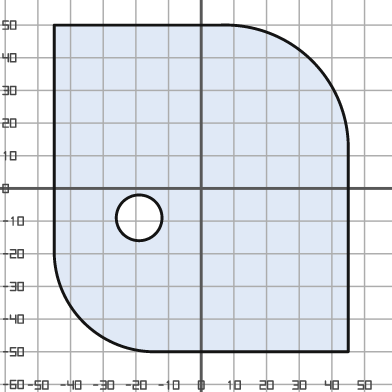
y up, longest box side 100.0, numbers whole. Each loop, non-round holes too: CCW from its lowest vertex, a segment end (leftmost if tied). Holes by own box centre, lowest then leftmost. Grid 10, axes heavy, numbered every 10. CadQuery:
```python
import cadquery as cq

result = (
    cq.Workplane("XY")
    .moveTo(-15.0, -50.0)
    .lineTo(45.0, -50.0)
    .lineTo(45.0, 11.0)
    .threePointArc((34.0, 39.0), (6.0, 50.0))
    .lineTo(-45.0, 50.0)
    .lineTo(-45.0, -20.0)
    .threePointArc((-36.0, -41.0), (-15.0, -50.0))
    .close()
    .moveTo(-19.0, -9.0)
    .circle(7.0)
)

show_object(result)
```